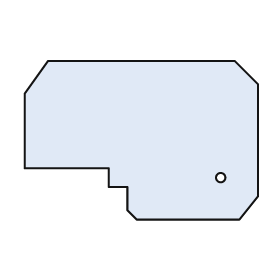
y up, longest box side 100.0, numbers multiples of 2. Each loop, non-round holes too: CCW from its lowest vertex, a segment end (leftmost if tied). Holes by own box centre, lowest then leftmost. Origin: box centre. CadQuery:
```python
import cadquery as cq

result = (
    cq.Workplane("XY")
    .moveTo(-2.0, -34.0)
    .lineTo(42.0, -34.0)
    .lineTo(50.0, -24.0)
    .lineTo(50.0, 24.0)
    .lineTo(40.0, 34.0)
    .lineTo(-40.0, 34.0)
    .lineTo(-50.0, 20.0)
    .lineTo(-50.0, -12.0)
    .lineTo(-14.0, -12.0)
    .lineTo(-14.0, -20.0)
    .lineTo(-6.0, -20.0)
    .lineTo(-6.0, -30.0)
    .close()
    .moveTo(34.0, -16.0)
    .circle(2.0)
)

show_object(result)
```